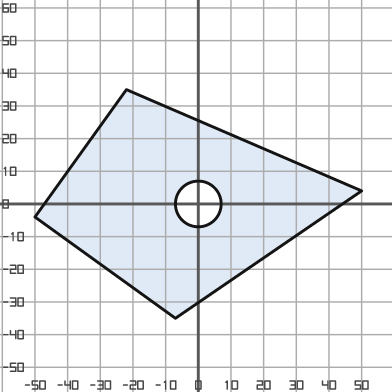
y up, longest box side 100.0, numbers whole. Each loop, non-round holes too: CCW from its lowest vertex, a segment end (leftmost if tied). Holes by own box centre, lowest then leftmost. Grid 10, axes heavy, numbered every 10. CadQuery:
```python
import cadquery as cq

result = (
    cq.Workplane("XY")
    .moveTo(-7.0, -35.0)
    .lineTo(50.0, 4.0)
    .lineTo(-22.0, 35.0)
    .lineTo(-50.0, -4.0)
    .close()
    .moveTo(0.0, 0.0)
    .circle(7.0)
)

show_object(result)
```